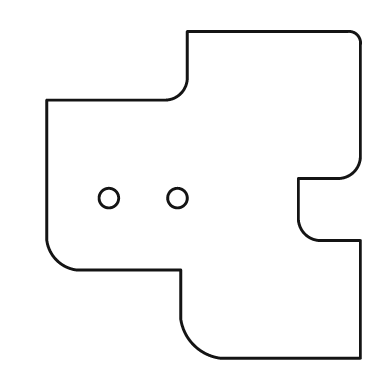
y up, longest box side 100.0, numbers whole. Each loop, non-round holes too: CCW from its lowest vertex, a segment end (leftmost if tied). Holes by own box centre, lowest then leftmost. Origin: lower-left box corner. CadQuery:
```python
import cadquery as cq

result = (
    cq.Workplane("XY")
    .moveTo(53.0, 0.0)
    .lineTo(96.0, 0.0)
    .lineTo(96.0, 36.0)
    .lineTo(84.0, 36.0)
    .threePointArc((79.0, 38.0), (77.0, 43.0))
    .lineTo(77.0, 55.0)
    .lineTo(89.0, 55.0)
    .threePointArc((94.0, 57.0), (96.0, 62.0))
    .lineTo(96.0, 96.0)
    .threePointArc((95.0, 99.0), (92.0, 100.0))
    .lineTo(43.0, 100.0)
    .lineTo(43.0, 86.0)
    .threePointArc((41.0, 81.0), (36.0, 79.0))
    .lineTo(0.0, 79.0)
    .lineTo(0.0, 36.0)
    .threePointArc((3.0, 30.0), (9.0, 27.0))
    .lineTo(41.0, 27.0)
    .lineTo(41.0, 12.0)
    .threePointArc((45.0, 4.0), (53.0, 0.0))
    .close()
    .moveTo(19.0, 49.0)
    .circle(3.0)
    .moveTo(40.0, 49.0)
    .circle(3.0)
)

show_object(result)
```